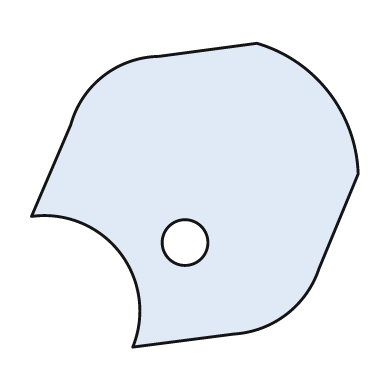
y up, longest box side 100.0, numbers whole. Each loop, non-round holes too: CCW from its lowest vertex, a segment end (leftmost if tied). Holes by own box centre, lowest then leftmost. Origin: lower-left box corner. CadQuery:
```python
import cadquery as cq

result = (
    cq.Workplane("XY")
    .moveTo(31.0, 0.0)
    .lineTo(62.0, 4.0)
    .threePointArc((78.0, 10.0), (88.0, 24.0))
    .lineTo(100.0, 53.0)
    .threePointArc((91.0, 78.0), (69.0, 93.0))
    .lineTo(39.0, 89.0)
    .threePointArc((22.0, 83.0), (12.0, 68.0))
    .lineTo(0.0, 40.0)
    .threePointArc((27.0, 29.0), (31.0, 0.0))
    .close()
    .moveTo(47.0, 32.0)
    .circle(7.0)
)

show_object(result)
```